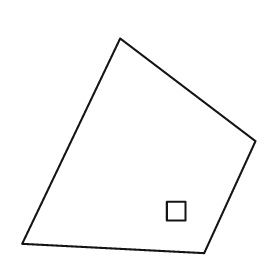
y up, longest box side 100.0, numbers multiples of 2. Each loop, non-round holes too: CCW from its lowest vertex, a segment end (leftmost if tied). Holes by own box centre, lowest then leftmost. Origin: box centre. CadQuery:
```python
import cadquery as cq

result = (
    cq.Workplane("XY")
    .moveTo(28.0, -46.0)
    .lineTo(50.0, 2.0)
    .lineTo(-8.0, 46.0)
    .lineTo(-50.0, -42.0)
    .close()
    .moveTo(12.0, -32.0)
    .lineTo(20.0, -32.0)
    .lineTo(20.0, -24.0)
    .lineTo(12.0, -24.0)
    .close()
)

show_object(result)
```